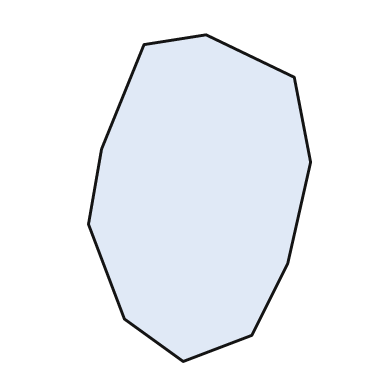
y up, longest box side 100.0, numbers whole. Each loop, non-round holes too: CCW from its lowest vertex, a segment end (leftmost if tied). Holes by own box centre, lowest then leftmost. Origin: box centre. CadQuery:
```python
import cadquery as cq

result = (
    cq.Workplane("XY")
    .moveTo(-5.0, -50.0)
    .lineTo(16.0, -42.0)
    .lineTo(27.0, -20.0)
    .lineTo(34.0, 11.0)
    .lineTo(29.0, 37.0)
    .lineTo(2.0, 50.0)
    .lineTo(-17.0, 47.0)
    .lineTo(-30.0, 15.0)
    .lineTo(-34.0, -8.0)
    .lineTo(-23.0, -37.0)
    .close()
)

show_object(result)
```